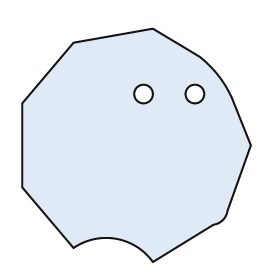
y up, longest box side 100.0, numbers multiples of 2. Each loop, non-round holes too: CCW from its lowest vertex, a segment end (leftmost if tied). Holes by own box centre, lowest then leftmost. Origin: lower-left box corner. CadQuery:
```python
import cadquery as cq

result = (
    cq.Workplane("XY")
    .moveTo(56.0, 0.0)
    .lineTo(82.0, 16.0)
    .threePointArc((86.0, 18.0), (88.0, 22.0))
    .lineTo(98.0, 50.0)
    .lineTo(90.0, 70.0)
    .threePointArc((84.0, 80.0), (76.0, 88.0))
    .lineTo(56.0, 100.0)
    .lineTo(22.0, 94.0)
    .lineTo(0.0, 68.0)
    .lineTo(0.0, 32.0)
    .lineTo(22.0, 6.0)
    .threePointArc((40.0, 10.0), (56.0, 0.0))
    .close()
    .moveTo(52.0, 72.0)
    .circle(4.0)
    .moveTo(74.0, 72.0)
    .circle(4.0)
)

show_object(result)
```